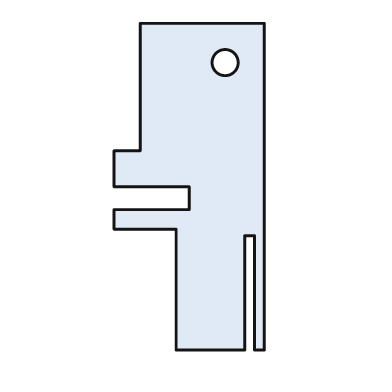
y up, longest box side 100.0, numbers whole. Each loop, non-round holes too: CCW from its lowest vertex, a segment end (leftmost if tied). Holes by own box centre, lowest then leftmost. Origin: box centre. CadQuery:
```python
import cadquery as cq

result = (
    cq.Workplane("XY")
    .moveTo(-4.0, -50.0)
    .lineTo(17.0, -50.0)
    .lineTo(17.0, -15.0)
    .lineTo(20.0, -15.0)
    .lineTo(20.0, -50.0)
    .lineTo(23.0, -50.0)
    .lineTo(23.0, 50.0)
    .lineTo(-15.0, 50.0)
    .lineTo(-15.0, 11.0)
    .lineTo(-23.0, 11.0)
    .lineTo(-23.0, 0.0)
    .lineTo(0.0, 0.0)
    .lineTo(0.0, -7.0)
    .lineTo(-23.0, -7.0)
    .lineTo(-23.0, -13.0)
    .lineTo(-4.0, -13.0)
    .close()
    .moveTo(11.0, 38.0)
    .circle(4.0)
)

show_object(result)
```